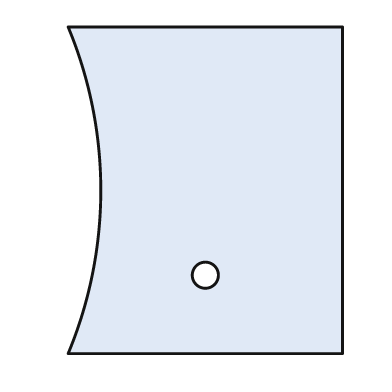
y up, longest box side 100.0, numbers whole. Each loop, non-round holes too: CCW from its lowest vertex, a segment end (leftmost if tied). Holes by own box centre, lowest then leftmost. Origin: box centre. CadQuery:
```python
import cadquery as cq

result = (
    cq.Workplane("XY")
    .moveTo(-42.0, -50.0)
    .lineTo(42.0, -50.0)
    .lineTo(42.0, 50.0)
    .lineTo(-42.0, 50.0)
    .threePointArc((-32.0, 0.0), (-42.0, -50.0))
    .close()
    .moveTo(0.0, -26.0)
    .circle(4.0)
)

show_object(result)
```